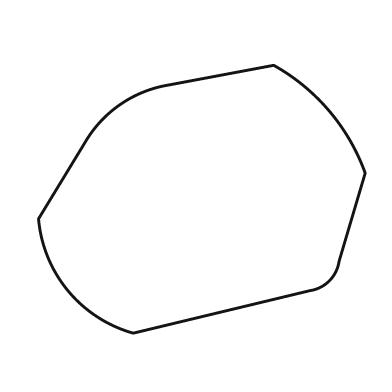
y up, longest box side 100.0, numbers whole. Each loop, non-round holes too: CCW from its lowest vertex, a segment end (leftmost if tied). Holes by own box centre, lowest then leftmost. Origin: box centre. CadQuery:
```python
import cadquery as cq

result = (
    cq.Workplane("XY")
    .moveTo(-21.0, -41.0)
    .lineTo(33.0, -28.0)
    .threePointArc((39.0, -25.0), (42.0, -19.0))
    .lineTo(50.0, 8.0)
    .threePointArc((39.0, 27.0), (22.0, 41.0))
    .lineTo(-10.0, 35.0)
    .threePointArc((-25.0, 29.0), (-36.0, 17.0))
    .lineTo(-50.0, -6.0)
    .threePointArc((-41.0, -28.0), (-21.0, -41.0))
    .close()
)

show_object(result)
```